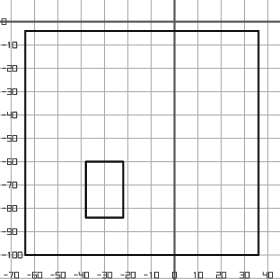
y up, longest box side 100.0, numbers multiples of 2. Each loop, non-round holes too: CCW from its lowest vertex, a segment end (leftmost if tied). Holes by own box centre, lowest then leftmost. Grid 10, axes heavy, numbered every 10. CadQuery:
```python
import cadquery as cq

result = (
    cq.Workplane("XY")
    .moveTo(-64.0, -100.0)
    .lineTo(36.0, -100.0)
    .lineTo(36.0, -4.0)
    .lineTo(-64.0, -4.0)
    .close()
    .moveTo(-38.0, -84.0)
    .lineTo(-22.0, -84.0)
    .lineTo(-22.0, -60.0)
    .lineTo(-38.0, -60.0)
    .close()
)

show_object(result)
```